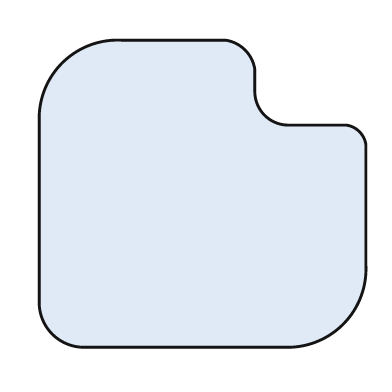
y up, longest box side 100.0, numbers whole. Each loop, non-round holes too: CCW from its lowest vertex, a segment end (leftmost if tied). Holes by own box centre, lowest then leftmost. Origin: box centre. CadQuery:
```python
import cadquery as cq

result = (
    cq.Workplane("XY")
    .moveTo(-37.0, -47.0)
    .lineTo(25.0, -47.0)
    .threePointArc((43.0, -40.0), (50.0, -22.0))
    .lineTo(50.0, 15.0)
    .threePointArc((48.0, 19.0), (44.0, 21.0))
    .lineTo(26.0, 21.0)
    .threePointArc((19.0, 24.0), (16.0, 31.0))
    .lineTo(16.0, 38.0)
    .threePointArc((13.0, 44.0), (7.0, 47.0))
    .lineTo(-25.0, 47.0)
    .threePointArc((-43.0, 40.0), (-50.0, 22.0))
    .lineTo(-50.0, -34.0)
    .threePointArc((-46.0, -43.0), (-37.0, -47.0))
    .close()
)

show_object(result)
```